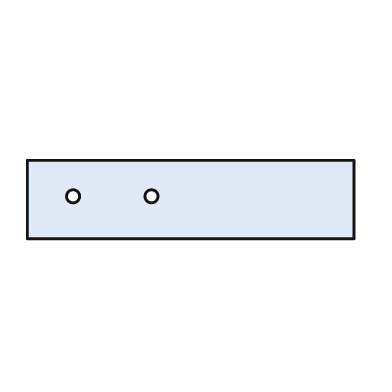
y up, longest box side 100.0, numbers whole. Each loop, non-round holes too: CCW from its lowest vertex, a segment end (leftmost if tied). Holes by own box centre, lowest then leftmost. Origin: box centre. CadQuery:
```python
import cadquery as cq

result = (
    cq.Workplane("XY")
    .moveTo(-50.0, -12.0)
    .lineTo(50.0, -12.0)
    .lineTo(50.0, 12.0)
    .lineTo(-50.0, 12.0)
    .close()
    .moveTo(-36.0, 1.0)
    .circle(2.0)
    .moveTo(-12.0, 1.0)
    .circle(2.0)
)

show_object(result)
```